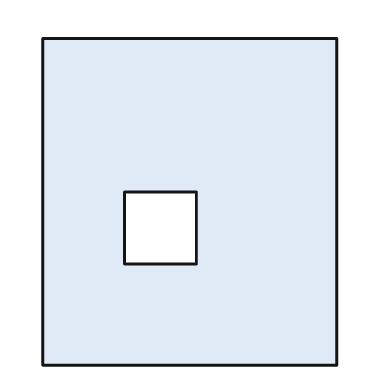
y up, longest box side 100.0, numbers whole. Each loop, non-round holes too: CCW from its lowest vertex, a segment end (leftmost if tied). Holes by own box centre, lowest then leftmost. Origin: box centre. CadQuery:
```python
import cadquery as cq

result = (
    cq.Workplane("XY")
    .moveTo(-45.0, -50.0)
    .lineTo(45.0, -50.0)
    .lineTo(45.0, 50.0)
    .lineTo(-45.0, 50.0)
    .close()
    .moveTo(-20.0, -19.0)
    .lineTo(2.0, -19.0)
    .lineTo(2.0, 3.0)
    .lineTo(-20.0, 3.0)
    .close()
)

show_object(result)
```